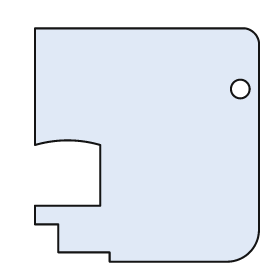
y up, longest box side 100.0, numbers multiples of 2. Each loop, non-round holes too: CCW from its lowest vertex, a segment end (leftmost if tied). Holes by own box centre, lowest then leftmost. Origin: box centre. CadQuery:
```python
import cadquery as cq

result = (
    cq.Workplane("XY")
    .moveTo(-16.0, -50.0)
    .lineTo(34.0, -50.0)
    .threePointArc((44.0, -46.0), (48.0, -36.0))
    .lineTo(48.0, 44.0)
    .threePointArc((46.0, 48.0), (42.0, 50.0))
    .lineTo(-48.0, 50.0)
    .lineTo(-48.0, 0.0)
    .threePointArc((-34.0, 2.0), (-20.0, 0.0))
    .lineTo(-20.0, -26.0)
    .lineTo(-48.0, -26.0)
    .lineTo(-48.0, -34.0)
    .lineTo(-38.0, -34.0)
    .lineTo(-38.0, -46.0)
    .lineTo(-16.0, -46.0)
    .close()
    .moveTo(40.0, 24.0)
    .circle(4.0)
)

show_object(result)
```